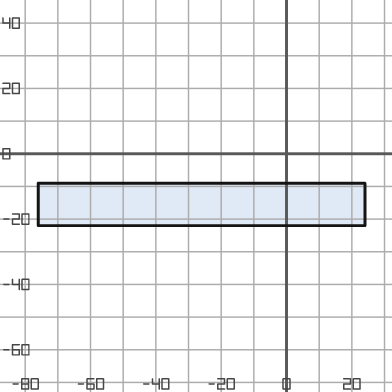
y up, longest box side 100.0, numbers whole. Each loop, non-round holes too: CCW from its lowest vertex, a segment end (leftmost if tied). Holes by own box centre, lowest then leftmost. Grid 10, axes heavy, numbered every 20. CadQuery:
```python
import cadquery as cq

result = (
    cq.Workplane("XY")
    .moveTo(-76.0, -22.0)
    .lineTo(24.0, -22.0)
    .lineTo(24.0, -9.0)
    .lineTo(-76.0, -9.0)
    .close()
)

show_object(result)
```